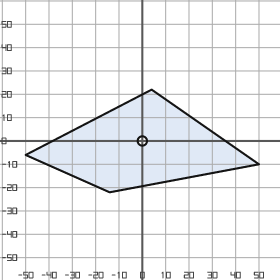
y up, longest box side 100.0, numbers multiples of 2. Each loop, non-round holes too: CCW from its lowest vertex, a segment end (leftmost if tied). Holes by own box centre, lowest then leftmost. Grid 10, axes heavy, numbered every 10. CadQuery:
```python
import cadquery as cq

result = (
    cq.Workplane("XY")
    .moveTo(-14.0, -22.0)
    .lineTo(50.0, -10.0)
    .lineTo(4.0, 22.0)
    .lineTo(-50.0, -6.0)
    .close()
    .moveTo(0.0, 0.0)
    .circle(2.0)
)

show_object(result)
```